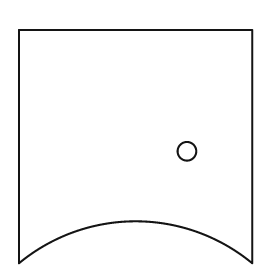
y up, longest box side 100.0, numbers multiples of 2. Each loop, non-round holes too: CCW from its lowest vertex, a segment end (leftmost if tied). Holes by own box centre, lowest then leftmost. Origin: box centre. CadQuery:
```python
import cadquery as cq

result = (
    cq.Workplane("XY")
    .moveTo(-50.0, -50.0)
    .threePointArc((0.0, -32.0), (50.0, -50.0))
    .lineTo(50.0, 50.0)
    .lineTo(-50.0, 50.0)
    .close()
    .moveTo(22.0, -2.0)
    .circle(4.0)
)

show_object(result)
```